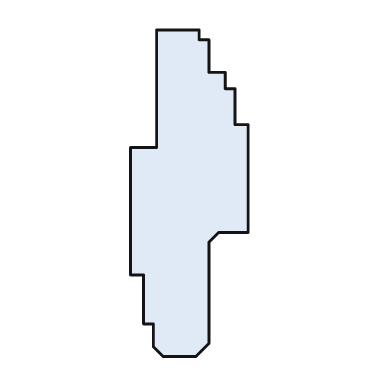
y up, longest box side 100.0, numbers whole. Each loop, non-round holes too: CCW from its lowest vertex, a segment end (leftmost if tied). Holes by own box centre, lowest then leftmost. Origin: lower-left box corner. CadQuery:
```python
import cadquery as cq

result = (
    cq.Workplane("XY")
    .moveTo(10.0, 0.0)
    .lineTo(20.0, 0.0)
    .lineTo(24.0, 4.0)
    .lineTo(24.0, 35.0)
    .lineTo(27.0, 38.0)
    .lineTo(36.0, 38.0)
    .lineTo(36.0, 71.0)
    .lineTo(32.0, 71.0)
    .lineTo(32.0, 82.0)
    .lineTo(29.0, 82.0)
    .lineTo(29.0, 87.0)
    .lineTo(24.0, 87.0)
    .lineTo(24.0, 97.0)
    .lineTo(21.0, 97.0)
    .lineTo(21.0, 100.0)
    .lineTo(8.0, 100.0)
    .lineTo(8.0, 64.0)
    .lineTo(0.0, 64.0)
    .lineTo(0.0, 25.0)
    .lineTo(4.0, 25.0)
    .lineTo(4.0, 10.0)
    .lineTo(7.0, 10.0)
    .lineTo(7.0, 3.0)
    .close()
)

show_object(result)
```